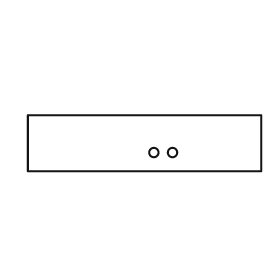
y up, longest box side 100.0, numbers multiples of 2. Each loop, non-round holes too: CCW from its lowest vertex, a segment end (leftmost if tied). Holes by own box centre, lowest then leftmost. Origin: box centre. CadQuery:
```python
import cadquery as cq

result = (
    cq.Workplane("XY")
    .moveTo(-50.0, -12.0)
    .lineTo(50.0, -12.0)
    .lineTo(50.0, 12.0)
    .lineTo(-50.0, 12.0)
    .close()
    .moveTo(4.0, -4.0)
    .circle(2.0)
    .moveTo(12.0, -4.0)
    .circle(2.0)
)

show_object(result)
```